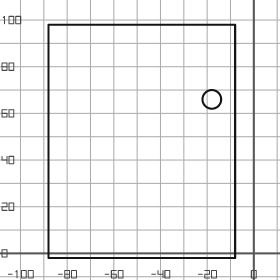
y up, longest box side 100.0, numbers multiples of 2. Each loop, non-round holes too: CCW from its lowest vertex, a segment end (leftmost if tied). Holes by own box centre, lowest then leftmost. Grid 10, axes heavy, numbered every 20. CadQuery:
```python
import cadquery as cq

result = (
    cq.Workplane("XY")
    .moveTo(-88.0, -2.0)
    .lineTo(-8.0, -2.0)
    .lineTo(-8.0, 98.0)
    .lineTo(-88.0, 98.0)
    .close()
    .moveTo(-18.0, 66.0)
    .circle(4.0)
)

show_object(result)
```